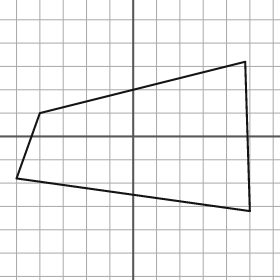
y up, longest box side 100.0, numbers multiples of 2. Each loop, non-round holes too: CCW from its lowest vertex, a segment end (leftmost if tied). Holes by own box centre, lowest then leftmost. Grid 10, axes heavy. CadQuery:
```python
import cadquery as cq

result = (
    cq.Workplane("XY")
    .moveTo(50.0, -32.0)
    .lineTo(48.0, 32.0)
    .lineTo(-40.0, 10.0)
    .lineTo(-50.0, -18.0)
    .close()
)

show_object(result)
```